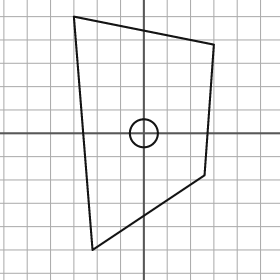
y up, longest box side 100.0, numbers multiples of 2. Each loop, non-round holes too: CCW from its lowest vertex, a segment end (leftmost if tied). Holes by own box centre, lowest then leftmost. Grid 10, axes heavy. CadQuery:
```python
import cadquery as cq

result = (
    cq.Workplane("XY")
    .moveTo(-22.0, -50.0)
    .lineTo(26.0, -18.0)
    .lineTo(30.0, 38.0)
    .lineTo(-30.0, 50.0)
    .close()
    .moveTo(0.0, 0.0)
    .circle(6.0)
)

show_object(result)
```